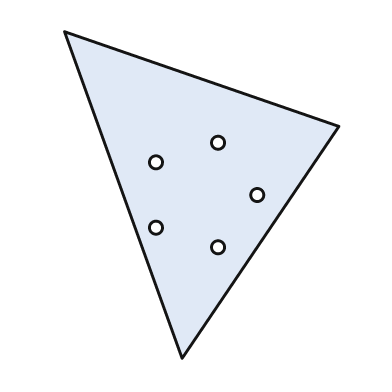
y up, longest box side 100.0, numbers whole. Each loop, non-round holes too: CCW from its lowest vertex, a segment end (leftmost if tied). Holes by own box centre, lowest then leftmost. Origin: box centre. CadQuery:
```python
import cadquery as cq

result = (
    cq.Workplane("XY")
    .moveTo(-6.0, -50.0)
    .lineTo(42.0, 21.0)
    .lineTo(-42.0, 50.0)
    .close()
    .moveTo(5.0, -16.0)
    .circle(2.0)
    .moveTo(-14.0, -10.0)
    .circle(2.0)
    .moveTo(17.0, 0.0)
    .circle(2.0)
    .moveTo(-14.0, 10.0)
    .circle(2.0)
    .moveTo(5.0, 16.0)
    .circle(2.0)
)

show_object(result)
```